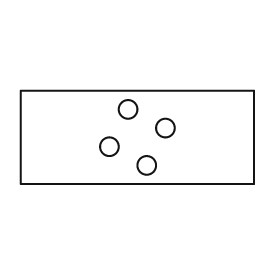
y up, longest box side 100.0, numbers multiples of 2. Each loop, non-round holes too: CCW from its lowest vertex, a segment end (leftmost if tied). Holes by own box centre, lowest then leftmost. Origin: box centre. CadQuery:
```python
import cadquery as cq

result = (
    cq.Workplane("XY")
    .moveTo(-50.0, -20.0)
    .lineTo(50.0, -20.0)
    .lineTo(50.0, 20.0)
    .lineTo(-50.0, 20.0)
    .close()
    .moveTo(4.0, -12.0)
    .circle(4.0)
    .moveTo(-12.0, -4.0)
    .circle(4.0)
    .moveTo(12.0, 4.0)
    .circle(4.0)
    .moveTo(-4.0, 12.0)
    .circle(4.0)
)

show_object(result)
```